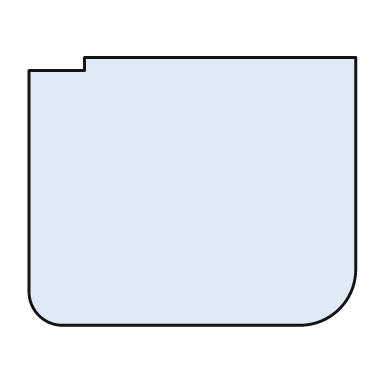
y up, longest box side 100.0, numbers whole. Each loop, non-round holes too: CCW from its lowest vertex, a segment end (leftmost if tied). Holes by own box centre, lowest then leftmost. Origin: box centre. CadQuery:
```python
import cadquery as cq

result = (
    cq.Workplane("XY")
    .moveTo(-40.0, -41.0)
    .lineTo(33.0, -41.0)
    .threePointArc((45.0, -36.0), (50.0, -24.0))
    .lineTo(50.0, 41.0)
    .lineTo(-33.0, 41.0)
    .lineTo(-33.0, 37.0)
    .lineTo(-50.0, 37.0)
    .lineTo(-50.0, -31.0)
    .threePointArc((-47.0, -38.0), (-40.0, -41.0))
    .close()
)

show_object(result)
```